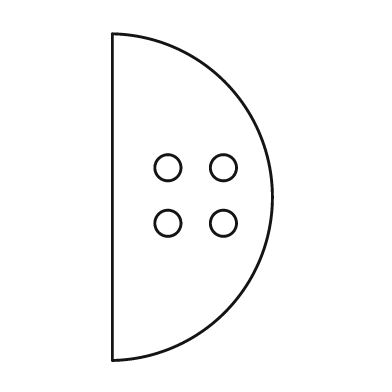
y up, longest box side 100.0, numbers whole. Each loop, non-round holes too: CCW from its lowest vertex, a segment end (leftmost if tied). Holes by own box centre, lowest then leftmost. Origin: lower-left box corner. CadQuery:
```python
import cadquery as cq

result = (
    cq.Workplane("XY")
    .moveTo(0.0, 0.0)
    .threePointArc((49.0, 50.0), (0.0, 100.0))
    .close()
    .moveTo(17.0, 42.0)
    .circle(4.0)
    .moveTo(34.0, 42.0)
    .circle(4.0)
    .moveTo(17.0, 59.0)
    .circle(4.0)
    .moveTo(34.0, 59.0)
    .circle(4.0)
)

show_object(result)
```